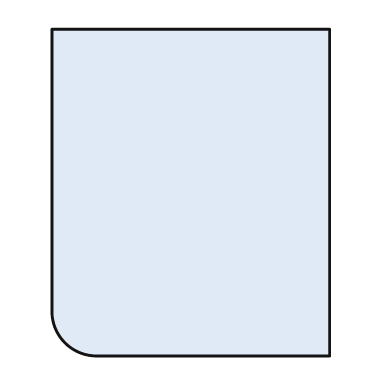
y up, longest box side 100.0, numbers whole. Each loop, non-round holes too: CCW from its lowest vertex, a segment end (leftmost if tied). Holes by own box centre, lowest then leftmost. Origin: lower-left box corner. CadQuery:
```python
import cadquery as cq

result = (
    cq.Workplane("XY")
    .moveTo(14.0, 0.0)
    .lineTo(85.0, 0.0)
    .lineTo(85.0, 100.0)
    .lineTo(0.0, 100.0)
    .lineTo(0.0, 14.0)
    .threePointArc((4.0, 4.0), (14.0, 0.0))
    .close()
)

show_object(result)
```